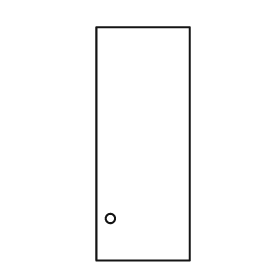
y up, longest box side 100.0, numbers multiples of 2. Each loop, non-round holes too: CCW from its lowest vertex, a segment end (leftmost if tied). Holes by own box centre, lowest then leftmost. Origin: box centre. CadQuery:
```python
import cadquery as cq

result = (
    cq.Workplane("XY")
    .moveTo(-20.0, -50.0)
    .lineTo(20.0, -50.0)
    .lineTo(20.0, 50.0)
    .lineTo(-20.0, 50.0)
    .close()
    .moveTo(-14.0, -32.0)
    .circle(2.0)
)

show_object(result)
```